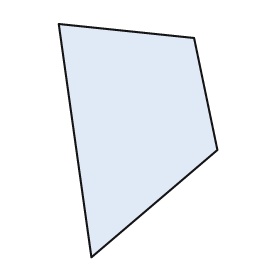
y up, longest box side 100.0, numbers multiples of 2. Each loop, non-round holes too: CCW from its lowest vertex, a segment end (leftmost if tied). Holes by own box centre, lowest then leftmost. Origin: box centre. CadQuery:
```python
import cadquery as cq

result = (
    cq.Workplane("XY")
    .moveTo(-20.0, -50.0)
    .lineTo(34.0, -4.0)
    .lineTo(24.0, 44.0)
    .lineTo(-34.0, 50.0)
    .close()
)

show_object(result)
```